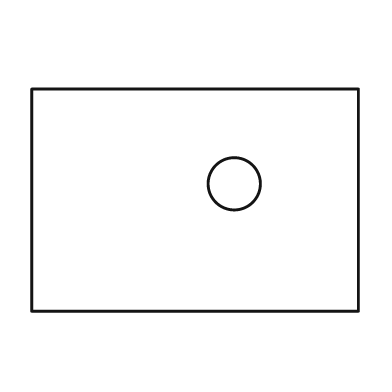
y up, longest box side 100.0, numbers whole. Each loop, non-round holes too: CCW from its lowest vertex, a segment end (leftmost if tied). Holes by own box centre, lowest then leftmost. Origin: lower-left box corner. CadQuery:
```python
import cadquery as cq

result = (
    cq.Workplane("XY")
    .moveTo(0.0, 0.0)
    .lineTo(100.0, 0.0)
    .lineTo(100.0, 68.0)
    .lineTo(0.0, 68.0)
    .close()
    .moveTo(62.0, 39.0)
    .circle(8.0)
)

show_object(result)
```